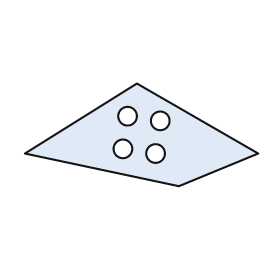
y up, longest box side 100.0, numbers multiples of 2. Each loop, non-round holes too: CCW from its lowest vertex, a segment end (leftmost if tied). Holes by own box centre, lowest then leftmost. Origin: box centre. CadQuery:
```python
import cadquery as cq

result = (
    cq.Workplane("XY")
    .moveTo(16.0, -22.0)
    .lineTo(50.0, -8.0)
    .lineTo(-2.0, 22.0)
    .lineTo(-50.0, -8.0)
    .close()
    .moveTo(6.0, -8.0)
    .circle(4.0)
    .moveTo(-8.0, -6.0)
    .circle(4.0)
    .moveTo(8.0, 6.0)
    .circle(4.0)
    .moveTo(-6.0, 8.0)
    .circle(4.0)
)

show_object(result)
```